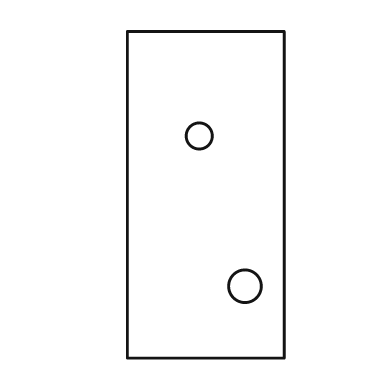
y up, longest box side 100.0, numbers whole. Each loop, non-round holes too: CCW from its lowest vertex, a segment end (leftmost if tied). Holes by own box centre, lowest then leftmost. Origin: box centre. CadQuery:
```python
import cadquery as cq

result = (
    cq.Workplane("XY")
    .moveTo(-24.0, -50.0)
    .lineTo(24.0, -50.0)
    .lineTo(24.0, 50.0)
    .lineTo(-24.0, 50.0)
    .close()
    .moveTo(12.0, -28.0)
    .circle(5.0)
    .moveTo(-2.0, 18.0)
    .circle(4.0)
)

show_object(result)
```